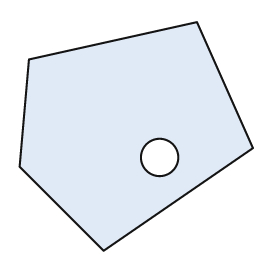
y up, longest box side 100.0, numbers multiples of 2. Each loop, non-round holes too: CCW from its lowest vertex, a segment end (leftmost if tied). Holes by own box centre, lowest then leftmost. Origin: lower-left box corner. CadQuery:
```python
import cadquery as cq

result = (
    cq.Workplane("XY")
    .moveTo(36.0, 0.0)
    .lineTo(100.0, 44.0)
    .lineTo(76.0, 98.0)
    .lineTo(4.0, 82.0)
    .lineTo(0.0, 36.0)
    .close()
    .moveTo(60.0, 40.0)
    .circle(8.0)
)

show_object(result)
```